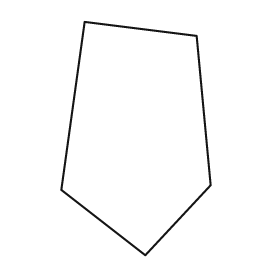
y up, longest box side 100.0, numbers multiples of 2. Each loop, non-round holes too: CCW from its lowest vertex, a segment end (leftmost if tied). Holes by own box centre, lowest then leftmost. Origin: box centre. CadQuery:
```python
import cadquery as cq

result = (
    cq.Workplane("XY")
    .moveTo(4.0, -50.0)
    .lineTo(32.0, -20.0)
    .lineTo(26.0, 44.0)
    .lineTo(-22.0, 50.0)
    .lineTo(-32.0, -22.0)
    .close()
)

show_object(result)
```